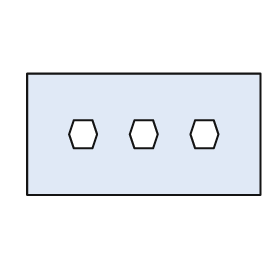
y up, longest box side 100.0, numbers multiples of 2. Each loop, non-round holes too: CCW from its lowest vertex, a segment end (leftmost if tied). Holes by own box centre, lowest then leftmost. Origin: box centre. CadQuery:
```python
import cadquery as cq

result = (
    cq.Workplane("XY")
    .moveTo(-50.0, -26.0)
    .lineTo(50.0, -26.0)
    .lineTo(50.0, 26.0)
    .lineTo(-50.0, 26.0)
    .close()
    .moveTo(-30.0, -6.0)
    .lineTo(-22.0, -6.0)
    .lineTo(-20.0, 0.0)
    .lineTo(-22.0, 6.0)
    .lineTo(-30.0, 6.0)
    .lineTo(-32.0, 0.0)
    .close()
    .moveTo(-4.0, -6.0)
    .lineTo(4.0, -6.0)
    .lineTo(6.0, 0.0)
    .lineTo(4.0, 6.0)
    .lineTo(-4.0, 6.0)
    .lineTo(-6.0, 0.0)
    .close()
    .moveTo(22.0, -6.0)
    .lineTo(30.0, -6.0)
    .lineTo(32.0, 0.0)
    .lineTo(30.0, 6.0)
    .lineTo(22.0, 6.0)
    .lineTo(20.0, 0.0)
    .close()
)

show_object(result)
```